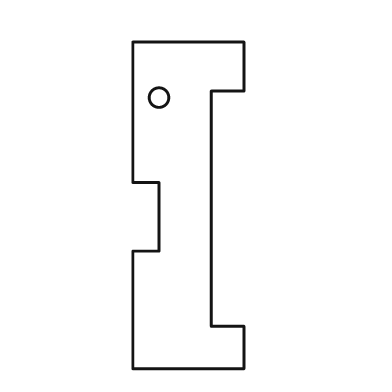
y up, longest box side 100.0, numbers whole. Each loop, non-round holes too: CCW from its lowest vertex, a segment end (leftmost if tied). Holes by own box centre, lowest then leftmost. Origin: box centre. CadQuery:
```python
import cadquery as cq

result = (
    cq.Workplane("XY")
    .moveTo(-17.0, -50.0)
    .lineTo(17.0, -50.0)
    .lineTo(17.0, -37.0)
    .lineTo(7.0, -37.0)
    .lineTo(7.0, 35.0)
    .lineTo(17.0, 35.0)
    .lineTo(17.0, 50.0)
    .lineTo(-17.0, 50.0)
    .lineTo(-17.0, 7.0)
    .lineTo(-9.0, 7.0)
    .lineTo(-9.0, -14.0)
    .lineTo(-17.0, -14.0)
    .close()
    .moveTo(-9.0, 33.0)
    .circle(3.0)
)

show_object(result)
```